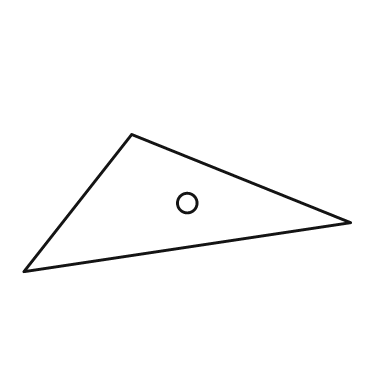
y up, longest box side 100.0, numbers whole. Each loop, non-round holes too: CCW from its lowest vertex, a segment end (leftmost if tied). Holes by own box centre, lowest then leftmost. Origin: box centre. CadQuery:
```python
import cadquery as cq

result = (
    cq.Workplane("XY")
    .moveTo(-50.0, -21.0)
    .lineTo(50.0, -6.0)
    .lineTo(-17.0, 21.0)
    .close()
    .moveTo(0.0, 0.0)
    .circle(3.0)
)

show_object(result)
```